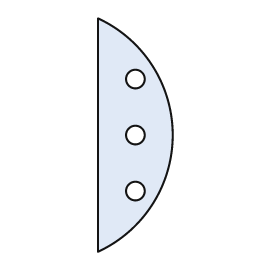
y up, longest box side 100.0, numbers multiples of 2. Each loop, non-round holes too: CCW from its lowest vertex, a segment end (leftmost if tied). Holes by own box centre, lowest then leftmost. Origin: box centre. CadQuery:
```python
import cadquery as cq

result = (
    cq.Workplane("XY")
    .moveTo(-16.0, -50.0)
    .threePointArc((16.0, 0.0), (-16.0, 50.0))
    .close()
    .moveTo(0.0, -24.0)
    .circle(4.0)
    .moveTo(0.0, 0.0)
    .circle(4.0)
    .moveTo(0.0, 24.0)
    .circle(4.0)
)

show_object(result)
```